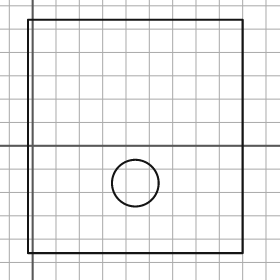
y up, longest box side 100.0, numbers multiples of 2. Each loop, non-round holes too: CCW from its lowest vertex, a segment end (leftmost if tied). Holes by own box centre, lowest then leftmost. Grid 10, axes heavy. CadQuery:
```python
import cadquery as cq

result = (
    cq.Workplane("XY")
    .moveTo(-2.0, -46.0)
    .lineTo(90.0, -46.0)
    .lineTo(90.0, 54.0)
    .lineTo(-2.0, 54.0)
    .close()
    .moveTo(44.0, -16.0)
    .circle(10.0)
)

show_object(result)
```